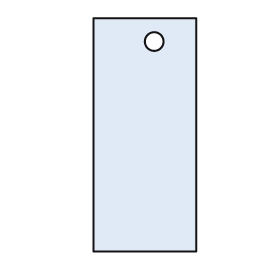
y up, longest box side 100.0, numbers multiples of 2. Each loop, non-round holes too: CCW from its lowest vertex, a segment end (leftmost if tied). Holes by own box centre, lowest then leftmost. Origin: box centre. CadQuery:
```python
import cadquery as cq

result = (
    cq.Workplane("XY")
    .moveTo(-22.0, -50.0)
    .lineTo(22.0, -50.0)
    .lineTo(22.0, 50.0)
    .lineTo(-22.0, 50.0)
    .close()
    .moveTo(4.0, 40.0)
    .circle(4.0)
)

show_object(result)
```